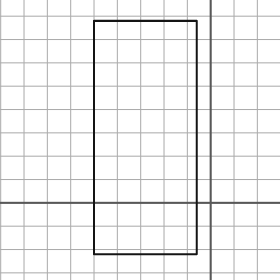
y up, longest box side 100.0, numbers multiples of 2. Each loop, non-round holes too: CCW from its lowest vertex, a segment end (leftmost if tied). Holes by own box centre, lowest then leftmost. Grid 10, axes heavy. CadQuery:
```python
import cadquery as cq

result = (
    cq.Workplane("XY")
    .moveTo(-50.0, -22.0)
    .lineTo(-6.0, -22.0)
    .lineTo(-6.0, 78.0)
    .lineTo(-50.0, 78.0)
    .close()
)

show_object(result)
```